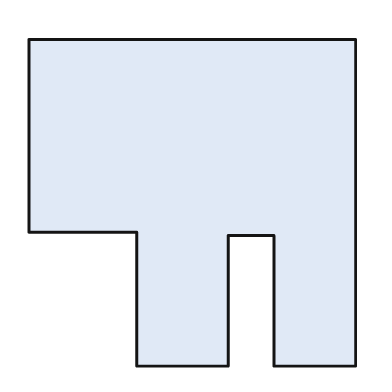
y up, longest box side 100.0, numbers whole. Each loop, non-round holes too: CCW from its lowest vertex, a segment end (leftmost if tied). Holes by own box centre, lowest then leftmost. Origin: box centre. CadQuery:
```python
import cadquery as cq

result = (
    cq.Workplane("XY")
    .moveTo(-17.0, -50.0)
    .lineTo(11.0, -50.0)
    .lineTo(11.0, -10.0)
    .lineTo(25.0, -10.0)
    .lineTo(25.0, -50.0)
    .lineTo(50.0, -50.0)
    .lineTo(50.0, 50.0)
    .lineTo(-50.0, 50.0)
    .lineTo(-50.0, -9.0)
    .lineTo(-17.0, -9.0)
    .close()
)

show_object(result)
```